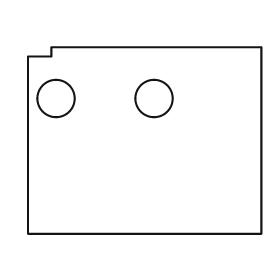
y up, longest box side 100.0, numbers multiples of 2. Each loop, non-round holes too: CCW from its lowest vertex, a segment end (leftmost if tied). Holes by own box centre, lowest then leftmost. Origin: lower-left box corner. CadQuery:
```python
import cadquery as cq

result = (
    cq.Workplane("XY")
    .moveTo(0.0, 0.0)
    .lineTo(100.0, 0.0)
    .lineTo(100.0, 80.0)
    .lineTo(10.0, 80.0)
    .lineTo(10.0, 76.0)
    .lineTo(0.0, 76.0)
    .close()
    .moveTo(12.0, 58.0)
    .circle(8.0)
    .moveTo(54.0, 58.0)
    .circle(8.0)
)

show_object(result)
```